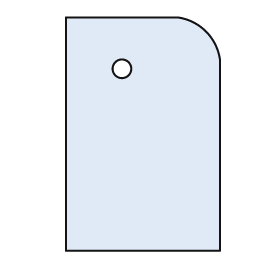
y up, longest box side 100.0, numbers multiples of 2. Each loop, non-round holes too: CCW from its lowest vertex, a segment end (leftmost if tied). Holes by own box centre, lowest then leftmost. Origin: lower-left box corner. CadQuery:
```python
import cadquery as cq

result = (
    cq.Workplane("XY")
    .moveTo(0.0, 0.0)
    .lineTo(66.0, 0.0)
    .lineTo(66.0, 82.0)
    .threePointArc((60.0, 94.0), (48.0, 100.0))
    .lineTo(0.0, 100.0)
    .close()
    .moveTo(24.0, 78.0)
    .circle(4.0)
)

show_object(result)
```